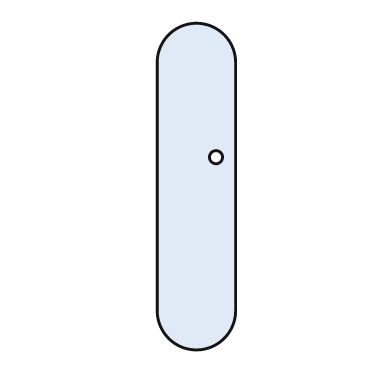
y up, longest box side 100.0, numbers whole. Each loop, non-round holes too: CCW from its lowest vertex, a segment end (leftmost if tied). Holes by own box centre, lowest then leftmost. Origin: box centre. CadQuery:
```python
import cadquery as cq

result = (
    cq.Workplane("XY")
    .moveTo(-12.0, -38.0)
    .threePointArc((0.0, -50.0), (12.0, -38.0))
    .lineTo(12.0, 38.0)
    .threePointArc((0.0, 50.0), (-12.0, 38.0))
    .close()
    .moveTo(6.0, 9.0)
    .circle(2.0)
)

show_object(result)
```